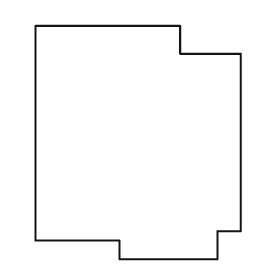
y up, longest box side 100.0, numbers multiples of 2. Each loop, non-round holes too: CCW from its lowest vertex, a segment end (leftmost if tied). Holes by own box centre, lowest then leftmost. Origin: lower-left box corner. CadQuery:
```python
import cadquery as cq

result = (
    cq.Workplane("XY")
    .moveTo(36.0, 0.0)
    .lineTo(78.0, 0.0)
    .lineTo(78.0, 12.0)
    .lineTo(88.0, 12.0)
    .lineTo(88.0, 88.0)
    .lineTo(62.0, 88.0)
    .lineTo(62.0, 100.0)
    .lineTo(0.0, 100.0)
    .lineTo(0.0, 8.0)
    .lineTo(36.0, 8.0)
    .close()
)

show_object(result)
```